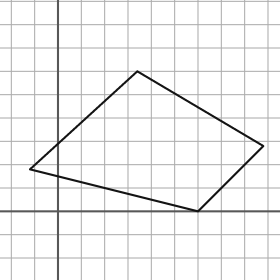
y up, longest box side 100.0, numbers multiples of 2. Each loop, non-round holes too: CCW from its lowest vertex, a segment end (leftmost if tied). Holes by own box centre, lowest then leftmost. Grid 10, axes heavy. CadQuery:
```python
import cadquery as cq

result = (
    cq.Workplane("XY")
    .moveTo(60.0, 0.0)
    .lineTo(88.0, 28.0)
    .lineTo(34.0, 60.0)
    .lineTo(-12.0, 18.0)
    .close()
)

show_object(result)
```